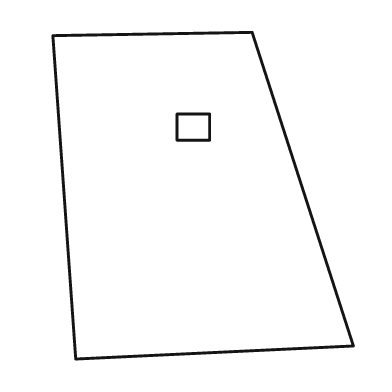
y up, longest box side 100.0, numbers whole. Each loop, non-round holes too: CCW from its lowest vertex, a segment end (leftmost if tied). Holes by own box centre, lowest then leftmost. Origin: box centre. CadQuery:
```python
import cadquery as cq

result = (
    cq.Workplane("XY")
    .moveTo(-39.0, -50.0)
    .lineTo(46.0, -46.0)
    .lineTo(15.0, 50.0)
    .lineTo(-46.0, 49.0)
    .close()
    .moveTo(-8.0, 17.0)
    .lineTo(2.0, 17.0)
    .lineTo(2.0, 25.0)
    .lineTo(-8.0, 25.0)
    .close()
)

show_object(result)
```